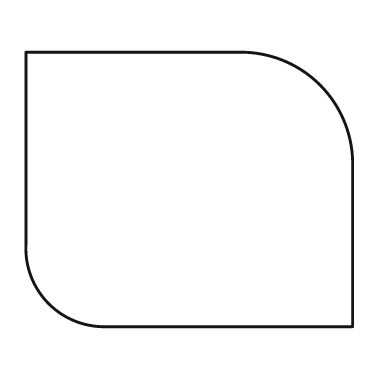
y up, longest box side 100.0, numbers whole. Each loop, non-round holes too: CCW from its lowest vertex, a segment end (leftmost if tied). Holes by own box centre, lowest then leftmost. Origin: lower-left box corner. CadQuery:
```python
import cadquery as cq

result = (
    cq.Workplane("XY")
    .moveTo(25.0, 0.0)
    .lineTo(100.0, 0.0)
    .lineTo(100.0, 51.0)
    .threePointArc((90.0, 74.0), (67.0, 84.0))
    .lineTo(0.0, 84.0)
    .lineTo(0.0, 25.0)
    .threePointArc((7.0, 7.0), (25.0, 0.0))
    .close()
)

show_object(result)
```